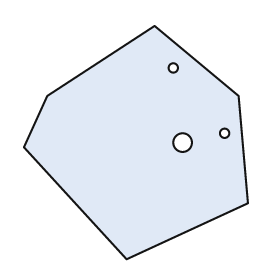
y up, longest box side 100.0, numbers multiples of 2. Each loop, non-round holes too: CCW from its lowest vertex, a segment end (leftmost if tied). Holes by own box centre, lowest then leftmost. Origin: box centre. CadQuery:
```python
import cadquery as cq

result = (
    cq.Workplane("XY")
    .moveTo(-4.0, -50.0)
    .lineTo(48.0, -26.0)
    .lineTo(44.0, 20.0)
    .lineTo(8.0, 50.0)
    .lineTo(-38.0, 20.0)
    .lineTo(-48.0, -2.0)
    .close()
    .moveTo(20.0, 0.0)
    .circle(4.0)
    .moveTo(38.0, 4.0)
    .circle(2.0)
    .moveTo(16.0, 32.0)
    .circle(2.0)
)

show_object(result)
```